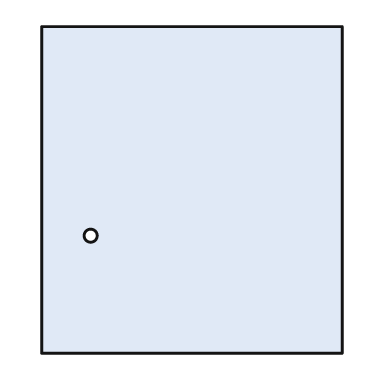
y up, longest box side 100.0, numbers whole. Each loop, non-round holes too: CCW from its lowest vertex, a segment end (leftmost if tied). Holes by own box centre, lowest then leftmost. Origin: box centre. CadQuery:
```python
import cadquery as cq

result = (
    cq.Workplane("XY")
    .moveTo(-46.0, -50.0)
    .lineTo(46.0, -50.0)
    .lineTo(46.0, 50.0)
    .lineTo(-46.0, 50.0)
    .close()
    .moveTo(-31.0, -14.0)
    .circle(2.0)
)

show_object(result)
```